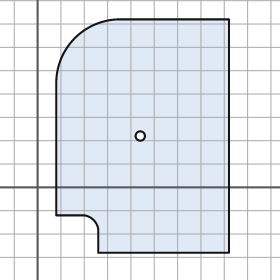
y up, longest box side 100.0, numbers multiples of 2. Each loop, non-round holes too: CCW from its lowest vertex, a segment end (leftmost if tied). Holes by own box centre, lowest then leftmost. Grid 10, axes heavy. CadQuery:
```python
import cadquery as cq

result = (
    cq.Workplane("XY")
    .moveTo(26.0, -28.0)
    .lineTo(82.0, -28.0)
    .lineTo(82.0, 72.0)
    .lineTo(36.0, 72.0)
    .threePointArc((16.0, 64.0), (8.0, 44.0))
    .lineTo(8.0, -12.0)
    .lineTo(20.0, -12.0)
    .threePointArc((24.0, -14.0), (26.0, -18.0))
    .close()
    .moveTo(44.0, 22.0)
    .circle(2.0)
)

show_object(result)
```